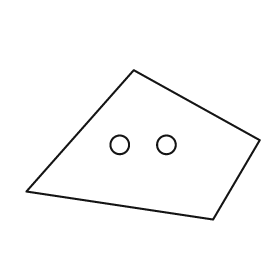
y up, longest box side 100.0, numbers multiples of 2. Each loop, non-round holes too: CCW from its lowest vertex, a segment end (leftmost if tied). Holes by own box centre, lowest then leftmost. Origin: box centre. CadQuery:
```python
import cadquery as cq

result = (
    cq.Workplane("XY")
    .moveTo(30.0, -32.0)
    .lineTo(50.0, 2.0)
    .lineTo(-4.0, 32.0)
    .lineTo(-50.0, -20.0)
    .close()
    .moveTo(-10.0, 0.0)
    .circle(4.0)
    .moveTo(10.0, 0.0)
    .circle(4.0)
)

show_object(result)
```